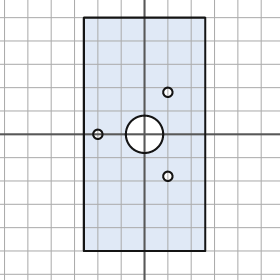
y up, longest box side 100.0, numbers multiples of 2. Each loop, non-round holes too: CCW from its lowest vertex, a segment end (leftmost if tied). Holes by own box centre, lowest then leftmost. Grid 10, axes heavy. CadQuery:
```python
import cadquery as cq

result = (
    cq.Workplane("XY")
    .moveTo(-26.0, -50.0)
    .lineTo(26.0, -50.0)
    .lineTo(26.0, 50.0)
    .lineTo(-26.0, 50.0)
    .close()
    .moveTo(10.0, -18.0)
    .circle(2.0)
    .moveTo(-20.0, 0.0)
    .circle(2.0)
    .moveTo(0.0, 0.0)
    .circle(8.0)
    .moveTo(10.0, 18.0)
    .circle(2.0)
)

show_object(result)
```